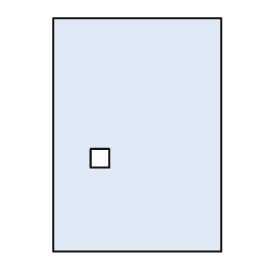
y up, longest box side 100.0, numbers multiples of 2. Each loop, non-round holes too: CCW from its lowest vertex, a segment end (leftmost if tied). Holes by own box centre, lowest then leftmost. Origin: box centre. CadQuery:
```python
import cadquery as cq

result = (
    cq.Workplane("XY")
    .moveTo(-36.0, -50.0)
    .lineTo(36.0, -50.0)
    .lineTo(36.0, 50.0)
    .lineTo(-36.0, 50.0)
    .close()
    .moveTo(-20.0, -14.0)
    .lineTo(-12.0, -14.0)
    .lineTo(-12.0, -6.0)
    .lineTo(-20.0, -6.0)
    .close()
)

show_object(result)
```